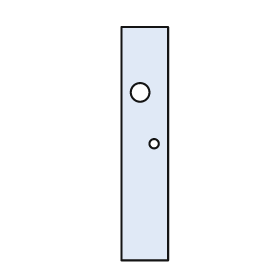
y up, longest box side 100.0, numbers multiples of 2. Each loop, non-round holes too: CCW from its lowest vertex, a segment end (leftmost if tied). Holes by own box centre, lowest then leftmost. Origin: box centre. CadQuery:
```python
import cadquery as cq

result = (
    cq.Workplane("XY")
    .moveTo(-10.0, -50.0)
    .lineTo(10.0, -50.0)
    .lineTo(10.0, 50.0)
    .lineTo(-10.0, 50.0)
    .close()
    .moveTo(4.0, 0.0)
    .circle(2.0)
    .moveTo(-2.0, 22.0)
    .circle(4.0)
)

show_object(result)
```